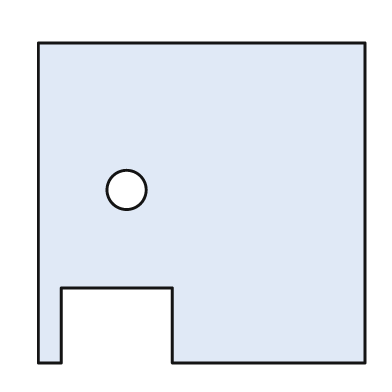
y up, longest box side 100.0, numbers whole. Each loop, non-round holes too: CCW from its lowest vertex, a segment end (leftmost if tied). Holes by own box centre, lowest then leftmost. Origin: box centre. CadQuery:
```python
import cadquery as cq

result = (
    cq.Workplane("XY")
    .moveTo(-50.0, -49.0)
    .lineTo(-43.0, -49.0)
    .lineTo(-43.0, -26.0)
    .lineTo(-9.0, -26.0)
    .lineTo(-9.0, -49.0)
    .lineTo(50.0, -49.0)
    .lineTo(50.0, 49.0)
    .lineTo(-50.0, 49.0)
    .close()
    .moveTo(-23.0, 4.0)
    .circle(6.0)
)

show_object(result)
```